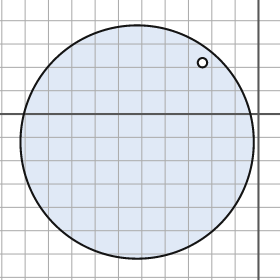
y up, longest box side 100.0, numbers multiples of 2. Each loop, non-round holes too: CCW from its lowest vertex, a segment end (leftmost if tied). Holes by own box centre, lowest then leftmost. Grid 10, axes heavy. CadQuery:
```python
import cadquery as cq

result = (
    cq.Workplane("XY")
    .moveTo(-52.0, -12.0)
    .circle(50.0)
    .moveTo(-24.0, 22.0)
    .circle(2.0)
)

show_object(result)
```